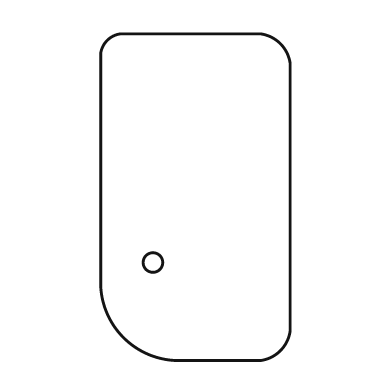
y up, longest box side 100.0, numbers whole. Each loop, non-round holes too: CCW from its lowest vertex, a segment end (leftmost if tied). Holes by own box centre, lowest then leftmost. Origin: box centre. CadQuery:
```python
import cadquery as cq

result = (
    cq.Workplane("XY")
    .moveTo(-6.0, -50.0)
    .lineTo(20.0, -50.0)
    .threePointArc((26.0, -47.0), (29.0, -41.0))
    .lineTo(29.0, 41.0)
    .threePointArc((26.0, 47.0), (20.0, 50.0))
    .lineTo(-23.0, 50.0)
    .threePointArc((-27.0, 48.0), (-29.0, 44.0))
    .lineTo(-29.0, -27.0)
    .threePointArc((-22.0, -43.0), (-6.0, -50.0))
    .close()
    .moveTo(-13.0, -20.0)
    .circle(3.0)
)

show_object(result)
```